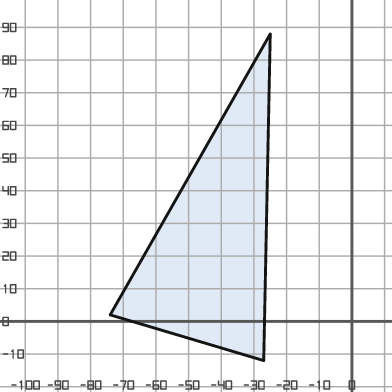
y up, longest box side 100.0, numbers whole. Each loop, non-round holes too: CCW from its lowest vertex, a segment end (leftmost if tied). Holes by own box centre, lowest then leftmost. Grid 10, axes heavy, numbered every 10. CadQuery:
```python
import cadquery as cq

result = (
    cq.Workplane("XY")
    .moveTo(-27.0, -12.0)
    .lineTo(-25.0, 88.0)
    .lineTo(-74.0, 2.0)
    .close()
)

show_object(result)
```